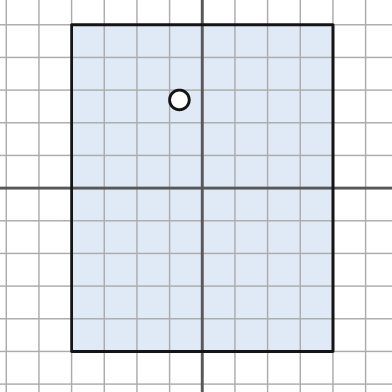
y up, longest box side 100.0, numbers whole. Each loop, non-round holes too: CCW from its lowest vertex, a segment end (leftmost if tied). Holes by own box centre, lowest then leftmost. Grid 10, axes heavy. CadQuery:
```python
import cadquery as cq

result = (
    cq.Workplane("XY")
    .moveTo(-40.0, -50.0)
    .lineTo(40.0, -50.0)
    .lineTo(40.0, 50.0)
    .lineTo(-40.0, 50.0)
    .close()
    .moveTo(-7.0, 27.0)
    .circle(3.0)
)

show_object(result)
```